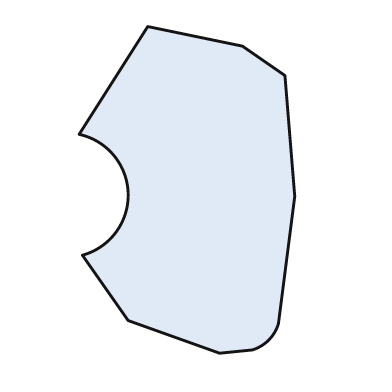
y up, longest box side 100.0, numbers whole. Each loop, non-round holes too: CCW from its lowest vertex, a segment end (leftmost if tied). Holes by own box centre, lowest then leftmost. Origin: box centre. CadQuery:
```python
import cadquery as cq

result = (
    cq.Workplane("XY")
    .moveTo(10.0, -50.0)
    .lineTo(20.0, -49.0)
    .threePointArc((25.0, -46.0), (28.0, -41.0))
    .lineTo(33.0, -2.0)
    .lineTo(30.0, 35.0)
    .lineTo(17.0, 44.0)
    .lineTo(-12.0, 50.0)
    .lineTo(-33.0, 17.0)
    .threePointArc((-18.0, -1.0), (-32.0, -20.0))
    .lineTo(-18.0, -40.0)
    .close()
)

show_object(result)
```